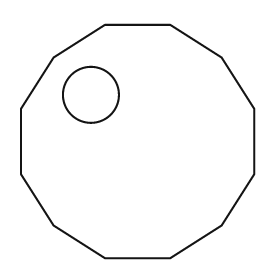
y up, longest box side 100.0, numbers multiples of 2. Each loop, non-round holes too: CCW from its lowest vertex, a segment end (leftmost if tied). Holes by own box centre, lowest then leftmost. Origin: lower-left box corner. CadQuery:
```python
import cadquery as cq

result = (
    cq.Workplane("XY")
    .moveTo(36.0, 0.0)
    .lineTo(64.0, 0.0)
    .lineTo(86.0, 14.0)
    .lineTo(100.0, 36.0)
    .lineTo(100.0, 64.0)
    .lineTo(86.0, 86.0)
    .lineTo(64.0, 100.0)
    .lineTo(36.0, 100.0)
    .lineTo(14.0, 86.0)
    .lineTo(0.0, 64.0)
    .lineTo(0.0, 36.0)
    .lineTo(14.0, 14.0)
    .close()
    .moveTo(30.0, 70.0)
    .circle(12.0)
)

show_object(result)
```